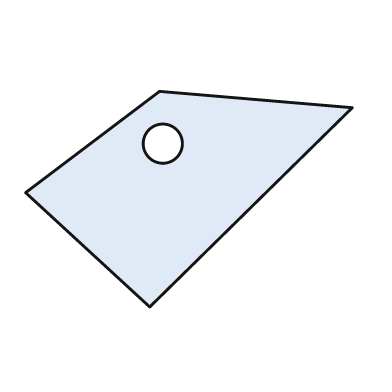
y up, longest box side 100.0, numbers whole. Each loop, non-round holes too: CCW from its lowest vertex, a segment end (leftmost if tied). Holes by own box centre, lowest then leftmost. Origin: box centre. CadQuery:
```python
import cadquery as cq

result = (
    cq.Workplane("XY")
    .moveTo(-12.0, -33.0)
    .lineTo(50.0, 28.0)
    .lineTo(-9.0, 33.0)
    .lineTo(-50.0, 2.0)
    .close()
    .moveTo(-8.0, 17.0)
    .circle(6.0)
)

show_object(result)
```